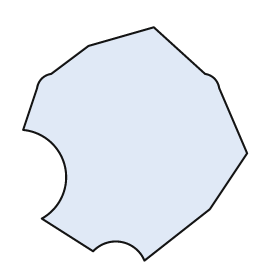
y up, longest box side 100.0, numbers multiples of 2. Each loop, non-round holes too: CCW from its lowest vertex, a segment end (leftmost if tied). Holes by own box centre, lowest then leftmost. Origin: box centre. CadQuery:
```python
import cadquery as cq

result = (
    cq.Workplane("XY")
    .moveTo(4.0, -50.0)
    .lineTo(32.0, -28.0)
    .lineTo(48.0, -4.0)
    .lineTo(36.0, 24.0)
    .threePointArc((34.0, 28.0), (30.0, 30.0))
    .lineTo(8.0, 50.0)
    .lineTo(-20.0, 42.0)
    .lineTo(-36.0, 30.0)
    .threePointArc((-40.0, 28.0), (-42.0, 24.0))
    .lineTo(-48.0, 6.0)
    .threePointArc((-30.0, -10.0), (-40.0, -32.0))
    .lineTo(-18.0, -46.0)
    .threePointArc((-6.0, -42.0), (4.0, -50.0))
    .close()
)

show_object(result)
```